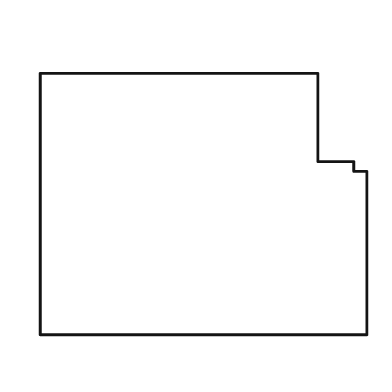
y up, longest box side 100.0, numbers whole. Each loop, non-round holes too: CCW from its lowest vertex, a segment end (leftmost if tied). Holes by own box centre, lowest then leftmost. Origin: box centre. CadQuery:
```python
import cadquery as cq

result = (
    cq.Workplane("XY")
    .moveTo(-50.0, -40.0)
    .lineTo(50.0, -40.0)
    .lineTo(50.0, 10.0)
    .lineTo(46.0, 10.0)
    .lineTo(46.0, 13.0)
    .lineTo(35.0, 13.0)
    .lineTo(35.0, 40.0)
    .lineTo(-50.0, 40.0)
    .close()
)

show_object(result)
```